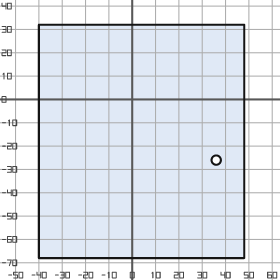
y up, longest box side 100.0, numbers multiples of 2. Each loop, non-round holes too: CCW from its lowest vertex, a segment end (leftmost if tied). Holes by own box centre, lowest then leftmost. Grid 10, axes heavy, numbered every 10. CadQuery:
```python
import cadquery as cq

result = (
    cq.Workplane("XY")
    .moveTo(-40.0, -68.0)
    .lineTo(48.0, -68.0)
    .lineTo(48.0, 32.0)
    .lineTo(-40.0, 32.0)
    .close()
    .moveTo(36.0, -26.0)
    .circle(2.0)
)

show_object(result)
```